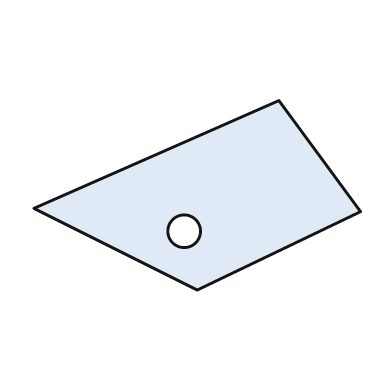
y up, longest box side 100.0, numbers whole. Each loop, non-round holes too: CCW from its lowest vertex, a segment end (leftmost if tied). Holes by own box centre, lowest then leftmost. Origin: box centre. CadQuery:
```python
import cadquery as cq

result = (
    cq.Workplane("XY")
    .moveTo(0.0, -29.0)
    .lineTo(50.0, -5.0)
    .lineTo(25.0, 29.0)
    .lineTo(-50.0, -4.0)
    .close()
    .moveTo(-4.0, -11.0)
    .circle(5.0)
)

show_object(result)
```